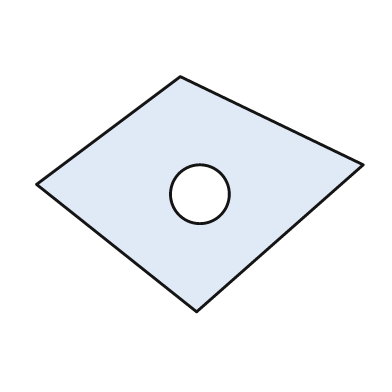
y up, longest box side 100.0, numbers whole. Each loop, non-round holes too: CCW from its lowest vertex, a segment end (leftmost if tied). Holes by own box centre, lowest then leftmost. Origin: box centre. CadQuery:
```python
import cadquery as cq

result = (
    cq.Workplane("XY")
    .moveTo(-1.0, -36.0)
    .lineTo(50.0, 9.0)
    .lineTo(-6.0, 36.0)
    .lineTo(-50.0, 3.0)
    .close()
    .moveTo(0.0, 0.0)
    .circle(9.0)
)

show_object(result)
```